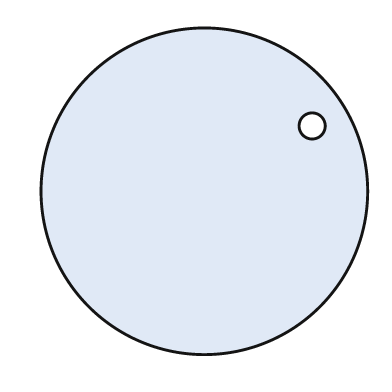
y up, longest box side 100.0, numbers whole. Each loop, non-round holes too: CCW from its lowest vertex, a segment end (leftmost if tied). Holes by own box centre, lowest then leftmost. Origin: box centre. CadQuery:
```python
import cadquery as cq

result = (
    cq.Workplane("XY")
    .moveTo(0.0, 0.0)
    .circle(50.0)
    .moveTo(33.0, 20.0)
    .circle(4.0)
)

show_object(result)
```